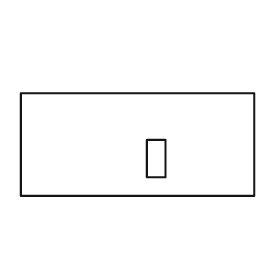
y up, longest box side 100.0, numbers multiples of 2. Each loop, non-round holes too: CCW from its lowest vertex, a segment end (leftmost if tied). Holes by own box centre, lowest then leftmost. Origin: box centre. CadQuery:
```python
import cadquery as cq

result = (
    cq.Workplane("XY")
    .moveTo(-50.0, -22.0)
    .lineTo(50.0, -22.0)
    .lineTo(50.0, 22.0)
    .lineTo(-50.0, 22.0)
    .close()
    .moveTo(4.0, -14.0)
    .lineTo(12.0, -14.0)
    .lineTo(12.0, 2.0)
    .lineTo(4.0, 2.0)
    .close()
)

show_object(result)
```